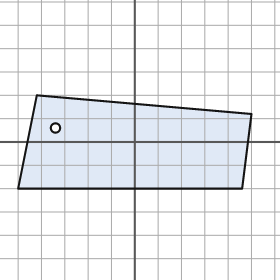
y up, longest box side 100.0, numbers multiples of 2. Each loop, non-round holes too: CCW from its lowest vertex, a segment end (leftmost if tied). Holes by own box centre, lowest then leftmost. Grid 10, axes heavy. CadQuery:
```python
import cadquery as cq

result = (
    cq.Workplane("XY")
    .moveTo(-50.0, -20.0)
    .lineTo(46.0, -20.0)
    .lineTo(50.0, 12.0)
    .lineTo(-42.0, 20.0)
    .close()
    .moveTo(-34.0, 6.0)
    .circle(2.0)
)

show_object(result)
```